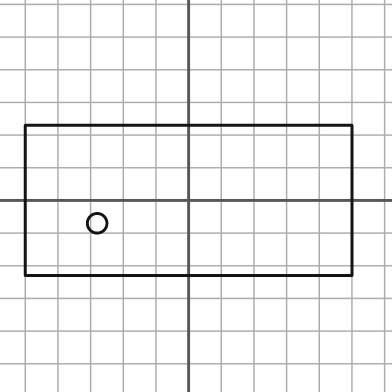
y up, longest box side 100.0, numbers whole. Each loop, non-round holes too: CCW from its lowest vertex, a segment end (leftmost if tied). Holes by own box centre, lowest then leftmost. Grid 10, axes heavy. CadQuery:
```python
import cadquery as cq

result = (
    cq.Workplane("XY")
    .moveTo(-50.0, -23.0)
    .lineTo(50.0, -23.0)
    .lineTo(50.0, 23.0)
    .lineTo(-50.0, 23.0)
    .close()
    .moveTo(-28.0, -7.0)
    .circle(3.0)
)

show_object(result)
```